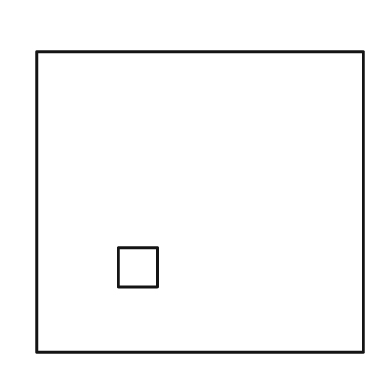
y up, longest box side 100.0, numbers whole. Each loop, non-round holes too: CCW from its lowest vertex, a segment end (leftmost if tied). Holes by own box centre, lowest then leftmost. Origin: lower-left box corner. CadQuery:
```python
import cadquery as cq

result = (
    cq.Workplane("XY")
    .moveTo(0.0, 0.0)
    .lineTo(100.0, 0.0)
    .lineTo(100.0, 92.0)
    .lineTo(0.0, 92.0)
    .close()
    .moveTo(25.0, 20.0)
    .lineTo(37.0, 20.0)
    .lineTo(37.0, 32.0)
    .lineTo(25.0, 32.0)
    .close()
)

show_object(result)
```